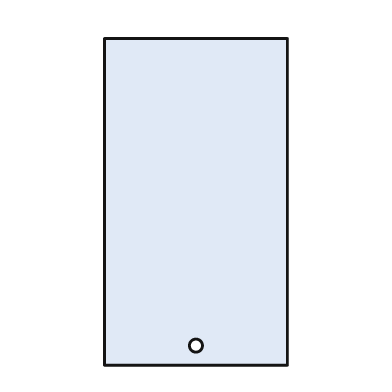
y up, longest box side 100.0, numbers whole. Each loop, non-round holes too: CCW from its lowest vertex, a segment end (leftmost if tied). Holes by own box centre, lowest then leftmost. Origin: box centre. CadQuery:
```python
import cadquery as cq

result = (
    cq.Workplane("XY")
    .moveTo(-28.0, -50.0)
    .lineTo(28.0, -50.0)
    .lineTo(28.0, 50.0)
    .lineTo(-28.0, 50.0)
    .close()
    .moveTo(0.0, -44.0)
    .circle(2.0)
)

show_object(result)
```